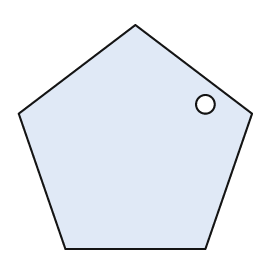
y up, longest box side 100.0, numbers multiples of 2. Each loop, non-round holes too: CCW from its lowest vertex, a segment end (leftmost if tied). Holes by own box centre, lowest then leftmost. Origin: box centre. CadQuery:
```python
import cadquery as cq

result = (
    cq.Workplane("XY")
    .moveTo(-30.0, -48.0)
    .lineTo(30.0, -48.0)
    .lineTo(50.0, 10.0)
    .lineTo(0.0, 48.0)
    .lineTo(-50.0, 10.0)
    .close()
    .moveTo(30.0, 14.0)
    .circle(4.0)
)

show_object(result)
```